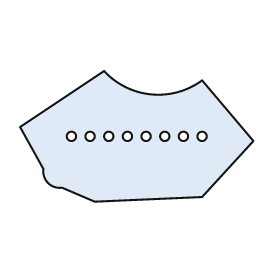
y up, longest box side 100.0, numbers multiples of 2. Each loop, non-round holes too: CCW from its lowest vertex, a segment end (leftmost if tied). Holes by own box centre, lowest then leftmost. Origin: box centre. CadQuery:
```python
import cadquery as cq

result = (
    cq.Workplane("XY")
    .moveTo(-18.0, -28.0)
    .lineTo(28.0, -26.0)
    .lineTo(50.0, -2.0)
    .lineTo(28.0, 24.0)
    .threePointArc((6.0, 18.0), (-14.0, 28.0))
    .lineTo(-50.0, 4.0)
    .lineTo(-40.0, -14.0)
    .threePointArc((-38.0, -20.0), (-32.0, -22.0))
    .close()
    .moveTo(-28.0, 0.0)
    .circle(2.0)
    .moveTo(-20.0, 0.0)
    .circle(2.0)
    .moveTo(-12.0, 0.0)
    .circle(2.0)
    .moveTo(-4.0, 0.0)
    .circle(2.0)
    .moveTo(4.0, 0.0)
    .circle(2.0)
    .moveTo(12.0, 0.0)
    .circle(2.0)
    .moveTo(20.0, 0.0)
    .circle(2.0)
    .moveTo(28.0, 0.0)
    .circle(2.0)
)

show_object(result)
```